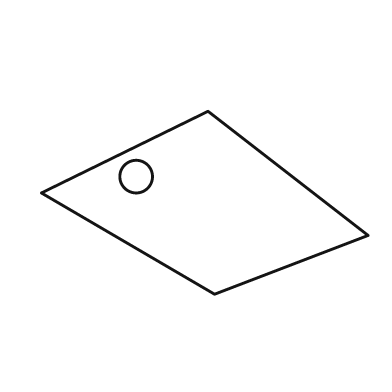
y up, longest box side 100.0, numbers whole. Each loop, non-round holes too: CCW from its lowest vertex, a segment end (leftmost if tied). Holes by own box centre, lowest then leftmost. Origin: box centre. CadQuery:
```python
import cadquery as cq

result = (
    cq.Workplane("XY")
    .moveTo(3.0, -28.0)
    .lineTo(50.0, -10.0)
    .lineTo(1.0, 28.0)
    .lineTo(-50.0, 3.0)
    .close()
    .moveTo(-21.0, 8.0)
    .circle(5.0)
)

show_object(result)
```